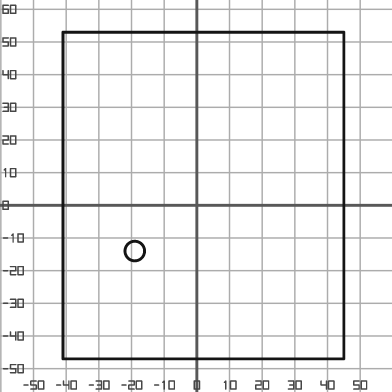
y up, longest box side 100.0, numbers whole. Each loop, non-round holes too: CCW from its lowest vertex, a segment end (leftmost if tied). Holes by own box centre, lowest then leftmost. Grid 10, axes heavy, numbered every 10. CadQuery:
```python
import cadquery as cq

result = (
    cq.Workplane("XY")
    .moveTo(-41.0, -47.0)
    .lineTo(45.0, -47.0)
    .lineTo(45.0, 53.0)
    .lineTo(-41.0, 53.0)
    .close()
    .moveTo(-19.0, -14.0)
    .circle(3.0)
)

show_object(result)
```